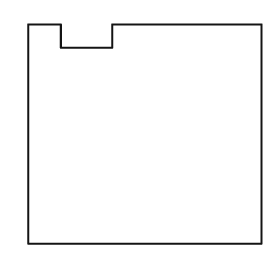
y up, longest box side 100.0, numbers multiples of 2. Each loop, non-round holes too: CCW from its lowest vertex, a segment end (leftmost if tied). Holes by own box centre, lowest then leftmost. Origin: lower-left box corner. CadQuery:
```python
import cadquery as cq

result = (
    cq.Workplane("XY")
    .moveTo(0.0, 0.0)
    .lineTo(100.0, 0.0)
    .lineTo(100.0, 94.0)
    .lineTo(36.0, 94.0)
    .lineTo(36.0, 84.0)
    .lineTo(14.0, 84.0)
    .lineTo(14.0, 94.0)
    .lineTo(0.0, 94.0)
    .close()
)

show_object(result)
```